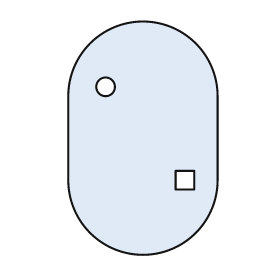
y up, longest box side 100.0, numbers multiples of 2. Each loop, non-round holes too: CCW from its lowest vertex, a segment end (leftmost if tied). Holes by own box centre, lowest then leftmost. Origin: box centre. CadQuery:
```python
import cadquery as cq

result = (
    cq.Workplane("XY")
    .moveTo(-32.0, -18.0)
    .threePointArc((0.0, -50.0), (32.0, -18.0))
    .lineTo(32.0, 18.0)
    .threePointArc((0.0, 50.0), (-32.0, 18.0))
    .close()
    .moveTo(14.0, -22.0)
    .lineTo(22.0, -22.0)
    .lineTo(22.0, -14.0)
    .lineTo(14.0, -14.0)
    .close()
    .moveTo(-16.0, 22.0)
    .circle(4.0)
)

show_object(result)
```